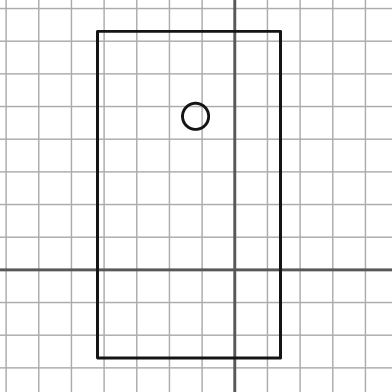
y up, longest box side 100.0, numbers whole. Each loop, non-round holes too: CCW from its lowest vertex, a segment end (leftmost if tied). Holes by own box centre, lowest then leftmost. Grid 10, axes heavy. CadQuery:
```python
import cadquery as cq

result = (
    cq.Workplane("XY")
    .moveTo(-42.0, -27.0)
    .lineTo(14.0, -27.0)
    .lineTo(14.0, 73.0)
    .lineTo(-42.0, 73.0)
    .close()
    .moveTo(-12.0, 47.0)
    .circle(4.0)
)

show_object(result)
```